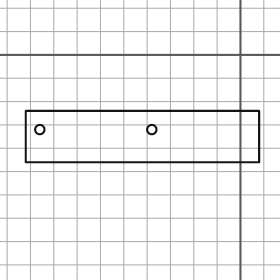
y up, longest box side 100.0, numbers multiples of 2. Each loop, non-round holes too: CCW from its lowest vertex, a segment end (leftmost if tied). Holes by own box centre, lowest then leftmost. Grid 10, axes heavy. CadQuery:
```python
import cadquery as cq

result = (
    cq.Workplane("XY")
    .moveTo(-92.0, -46.0)
    .lineTo(8.0, -46.0)
    .lineTo(8.0, -24.0)
    .lineTo(-92.0, -24.0)
    .close()
    .moveTo(-86.0, -32.0)
    .circle(2.0)
    .moveTo(-38.0, -32.0)
    .circle(2.0)
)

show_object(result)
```